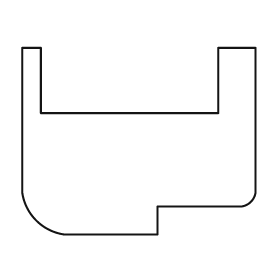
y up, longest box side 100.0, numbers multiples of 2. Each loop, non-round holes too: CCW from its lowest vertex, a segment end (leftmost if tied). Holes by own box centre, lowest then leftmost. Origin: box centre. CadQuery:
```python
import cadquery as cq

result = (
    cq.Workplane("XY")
    .moveTo(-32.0, -40.0)
    .lineTo(8.0, -40.0)
    .lineTo(8.0, -28.0)
    .lineTo(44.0, -28.0)
    .threePointArc((48.0, -26.0), (50.0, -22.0))
    .lineTo(50.0, 40.0)
    .lineTo(34.0, 40.0)
    .lineTo(34.0, 12.0)
    .lineTo(-42.0, 12.0)
    .lineTo(-42.0, 40.0)
    .lineTo(-50.0, 40.0)
    .lineTo(-50.0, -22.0)
    .threePointArc((-44.0, -34.0), (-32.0, -40.0))
    .close()
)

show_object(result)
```